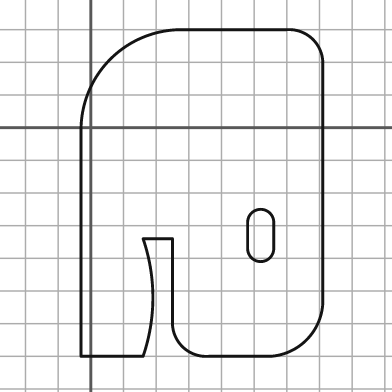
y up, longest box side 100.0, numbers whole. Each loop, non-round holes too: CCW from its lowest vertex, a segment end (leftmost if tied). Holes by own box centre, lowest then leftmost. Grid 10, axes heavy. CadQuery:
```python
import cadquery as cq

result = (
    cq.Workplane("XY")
    .moveTo(-3.0, -70.0)
    .lineTo(16.0, -70.0)
    .threePointArc((19.0, -52.0), (16.0, -34.0))
    .lineTo(25.0, -34.0)
    .lineTo(25.0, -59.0)
    .threePointArc((28.0, -67.0), (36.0, -70.0))
    .lineTo(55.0, -70.0)
    .threePointArc((66.0, -65.0), (71.0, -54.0))
    .lineTo(71.0, 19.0)
    .threePointArc((68.0, 27.0), (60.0, 30.0))
    .lineTo(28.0, 30.0)
    .threePointArc((6.0, 21.0), (-3.0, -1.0))
    .close()
    .moveTo(48.0, -37.0)
    .threePointArc((52.0, -41.0), (56.0, -37.0))
    .lineTo(56.0, -29.0)
    .threePointArc((52.0, -25.0), (48.0, -29.0))
    .close()
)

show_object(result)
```